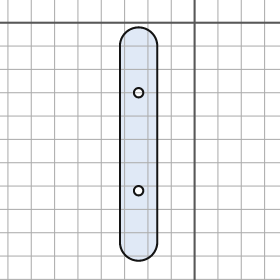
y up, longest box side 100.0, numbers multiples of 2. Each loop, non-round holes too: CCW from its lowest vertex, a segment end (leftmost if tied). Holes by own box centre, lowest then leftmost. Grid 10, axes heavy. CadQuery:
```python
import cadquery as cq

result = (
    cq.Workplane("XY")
    .moveTo(-32.0, -94.0)
    .threePointArc((-24.0, -102.0), (-16.0, -94.0))
    .lineTo(-16.0, -10.0)
    .threePointArc((-24.0, -2.0), (-32.0, -10.0))
    .close()
    .moveTo(-24.0, -72.0)
    .circle(2.0)
    .moveTo(-24.0, -30.0)
    .circle(2.0)
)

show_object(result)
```